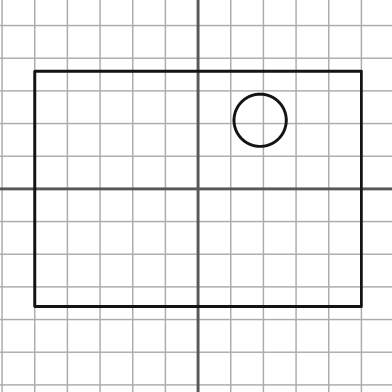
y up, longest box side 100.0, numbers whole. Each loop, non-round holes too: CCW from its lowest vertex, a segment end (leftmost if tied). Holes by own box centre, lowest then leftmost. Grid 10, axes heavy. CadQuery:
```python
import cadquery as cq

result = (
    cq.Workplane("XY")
    .moveTo(-50.0, -36.0)
    .lineTo(50.0, -36.0)
    .lineTo(50.0, 36.0)
    .lineTo(-50.0, 36.0)
    .close()
    .moveTo(19.0, 21.0)
    .circle(8.0)
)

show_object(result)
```